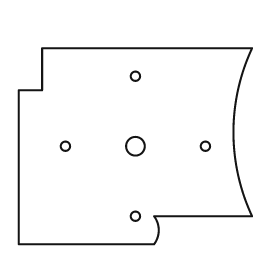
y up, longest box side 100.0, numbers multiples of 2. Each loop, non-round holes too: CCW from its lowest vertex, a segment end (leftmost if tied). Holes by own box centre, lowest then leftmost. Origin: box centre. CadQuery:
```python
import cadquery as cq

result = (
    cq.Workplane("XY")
    .moveTo(-50.0, -42.0)
    .lineTo(8.0, -42.0)
    .threePointArc((10.0, -36.0), (8.0, -30.0))
    .lineTo(50.0, -30.0)
    .threePointArc((42.0, 6.0), (50.0, 42.0))
    .lineTo(-40.0, 42.0)
    .lineTo(-40.0, 24.0)
    .lineTo(-50.0, 24.0)
    .close()
    .moveTo(0.0, -30.0)
    .circle(2.0)
    .moveTo(-30.0, 0.0)
    .circle(2.0)
    .moveTo(0.0, 0.0)
    .circle(4.0)
    .moveTo(30.0, 0.0)
    .circle(2.0)
    .moveTo(0.0, 30.0)
    .circle(2.0)
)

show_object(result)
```